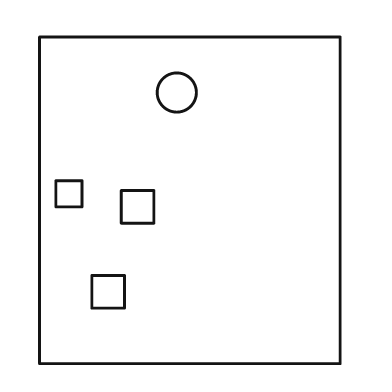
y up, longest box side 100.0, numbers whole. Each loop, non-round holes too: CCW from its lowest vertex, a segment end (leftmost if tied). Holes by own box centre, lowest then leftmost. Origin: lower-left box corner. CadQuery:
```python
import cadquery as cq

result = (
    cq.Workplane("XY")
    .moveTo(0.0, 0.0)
    .lineTo(92.0, 0.0)
    .lineTo(92.0, 100.0)
    .lineTo(0.0, 100.0)
    .close()
    .moveTo(16.0, 17.0)
    .lineTo(26.0, 17.0)
    .lineTo(26.0, 27.0)
    .lineTo(16.0, 27.0)
    .close()
    .moveTo(25.0, 43.0)
    .lineTo(35.0, 43.0)
    .lineTo(35.0, 53.0)
    .lineTo(25.0, 53.0)
    .close()
    .moveTo(5.0, 48.0)
    .lineTo(13.0, 48.0)
    .lineTo(13.0, 56.0)
    .lineTo(5.0, 56.0)
    .close()
    .moveTo(42.0, 83.0)
    .circle(6.0)
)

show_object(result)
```